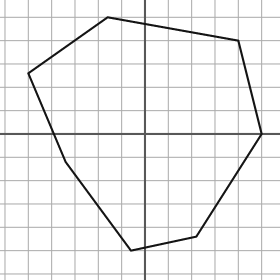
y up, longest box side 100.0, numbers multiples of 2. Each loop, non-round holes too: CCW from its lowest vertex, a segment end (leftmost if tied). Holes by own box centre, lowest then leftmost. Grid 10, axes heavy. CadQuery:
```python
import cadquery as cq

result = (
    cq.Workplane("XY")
    .moveTo(-6.0, -50.0)
    .lineTo(22.0, -44.0)
    .lineTo(50.0, 0.0)
    .lineTo(40.0, 40.0)
    .lineTo(-16.0, 50.0)
    .lineTo(-50.0, 26.0)
    .lineTo(-34.0, -12.0)
    .close()
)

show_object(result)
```